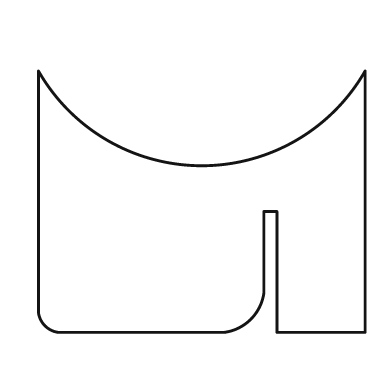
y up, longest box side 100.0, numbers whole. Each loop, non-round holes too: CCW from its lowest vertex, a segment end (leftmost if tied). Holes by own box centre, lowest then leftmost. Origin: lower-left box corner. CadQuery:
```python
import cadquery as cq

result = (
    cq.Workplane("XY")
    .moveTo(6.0, 0.0)
    .lineTo(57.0, 0.0)
    .threePointArc((65.0, 4.0), (69.0, 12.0))
    .lineTo(69.0, 37.0)
    .lineTo(73.0, 37.0)
    .lineTo(73.0, 0.0)
    .lineTo(100.0, 0.0)
    .lineTo(100.0, 80.0)
    .threePointArc((50.0, 51.0), (0.0, 80.0))
    .lineTo(0.0, 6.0)
    .threePointArc((2.0, 2.0), (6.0, 0.0))
    .close()
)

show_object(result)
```